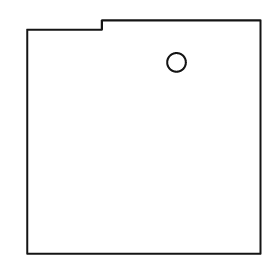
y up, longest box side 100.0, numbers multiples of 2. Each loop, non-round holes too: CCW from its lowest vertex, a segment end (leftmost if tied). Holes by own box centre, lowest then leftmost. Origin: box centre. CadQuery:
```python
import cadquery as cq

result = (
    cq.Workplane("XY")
    .moveTo(-50.0, -50.0)
    .lineTo(50.0, -50.0)
    .lineTo(50.0, 50.0)
    .lineTo(-18.0, 50.0)
    .lineTo(-18.0, 46.0)
    .lineTo(-50.0, 46.0)
    .close()
    .moveTo(14.0, 32.0)
    .circle(4.0)
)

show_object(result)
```